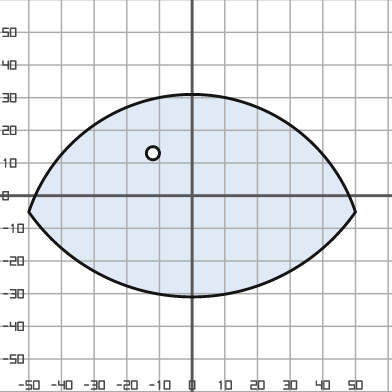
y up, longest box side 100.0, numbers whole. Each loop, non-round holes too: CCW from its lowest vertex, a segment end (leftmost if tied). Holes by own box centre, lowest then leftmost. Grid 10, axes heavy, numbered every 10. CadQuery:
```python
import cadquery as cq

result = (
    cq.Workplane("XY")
    .moveTo(-50.0, -5.0)
    .threePointArc((0.0, -31.0), (50.0, -5.0))
    .threePointArc((0.0, 31.0), (-50.0, -5.0))
    .close()
    .moveTo(-12.0, 13.0)
    .circle(2.0)
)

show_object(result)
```